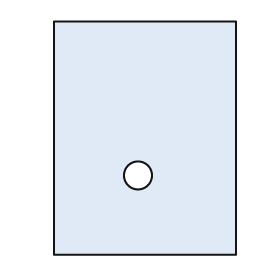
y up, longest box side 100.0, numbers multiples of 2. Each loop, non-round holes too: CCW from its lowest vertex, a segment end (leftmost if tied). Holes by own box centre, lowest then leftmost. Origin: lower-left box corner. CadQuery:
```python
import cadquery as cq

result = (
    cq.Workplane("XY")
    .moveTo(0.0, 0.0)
    .lineTo(78.0, 0.0)
    .lineTo(78.0, 100.0)
    .lineTo(0.0, 100.0)
    .close()
    .moveTo(36.0, 34.0)
    .circle(6.0)
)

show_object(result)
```